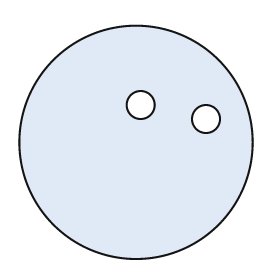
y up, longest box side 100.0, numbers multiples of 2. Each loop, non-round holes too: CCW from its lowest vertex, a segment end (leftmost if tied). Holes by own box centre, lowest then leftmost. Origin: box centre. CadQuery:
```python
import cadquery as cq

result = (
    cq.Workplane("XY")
    .moveTo(0.0, 0.0)
    .circle(50.0)
    .moveTo(30.0, 10.0)
    .circle(6.0)
    .moveTo(2.0, 16.0)
    .circle(6.0)
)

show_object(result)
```